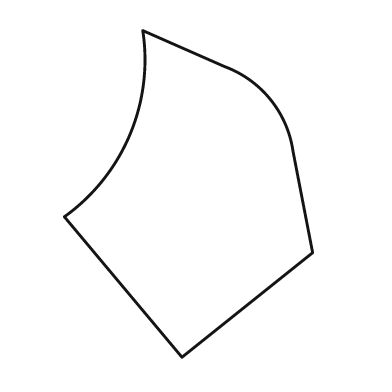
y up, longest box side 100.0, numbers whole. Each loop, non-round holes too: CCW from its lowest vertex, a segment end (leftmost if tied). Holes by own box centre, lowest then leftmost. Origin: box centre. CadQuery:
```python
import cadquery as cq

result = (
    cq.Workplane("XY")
    .moveTo(-2.0, -50.0)
    .lineTo(38.0, -18.0)
    .lineTo(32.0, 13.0)
    .threePointArc((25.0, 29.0), (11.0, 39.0))
    .lineTo(-14.0, 50.0)
    .threePointArc((-18.0, 18.0), (-38.0, -7.0))
    .close()
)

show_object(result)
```